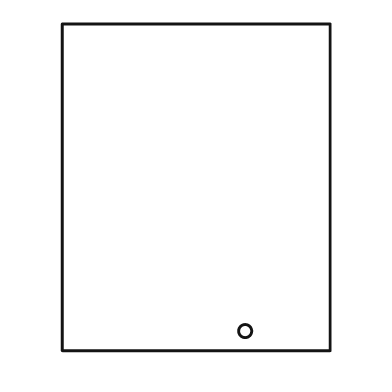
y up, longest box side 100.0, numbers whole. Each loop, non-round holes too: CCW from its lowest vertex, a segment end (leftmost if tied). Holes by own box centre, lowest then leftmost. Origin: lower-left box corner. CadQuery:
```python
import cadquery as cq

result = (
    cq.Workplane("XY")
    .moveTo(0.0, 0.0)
    .lineTo(82.0, 0.0)
    .lineTo(82.0, 100.0)
    .lineTo(0.0, 100.0)
    .close()
    .moveTo(56.0, 6.0)
    .circle(2.0)
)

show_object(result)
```